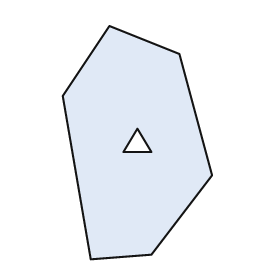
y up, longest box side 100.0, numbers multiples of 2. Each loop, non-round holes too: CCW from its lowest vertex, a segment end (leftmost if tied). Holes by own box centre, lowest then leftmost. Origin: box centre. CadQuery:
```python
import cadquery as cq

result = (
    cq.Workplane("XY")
    .moveTo(-20.0, -50.0)
    .lineTo(6.0, -48.0)
    .lineTo(32.0, -14.0)
    .lineTo(18.0, 38.0)
    .lineTo(-12.0, 50.0)
    .lineTo(-32.0, 20.0)
    .close()
    .moveTo(-6.0, -4.0)
    .lineTo(6.0, -4.0)
    .lineTo(0.0, 6.0)
    .close()
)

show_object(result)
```